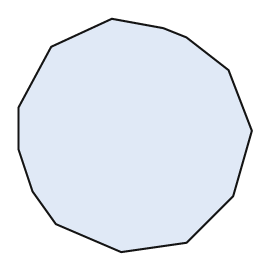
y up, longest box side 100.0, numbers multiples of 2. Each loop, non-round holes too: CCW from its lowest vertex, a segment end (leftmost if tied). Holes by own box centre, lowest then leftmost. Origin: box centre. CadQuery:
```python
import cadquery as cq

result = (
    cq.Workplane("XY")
    .moveTo(-6.0, -50.0)
    .lineTo(22.0, -46.0)
    .lineTo(42.0, -26.0)
    .lineTo(50.0, 2.0)
    .lineTo(40.0, 28.0)
    .lineTo(22.0, 42.0)
    .lineTo(12.0, 46.0)
    .lineTo(-10.0, 50.0)
    .lineTo(-36.0, 38.0)
    .lineTo(-50.0, 12.0)
    .lineTo(-50.0, -6.0)
    .lineTo(-44.0, -24.0)
    .lineTo(-34.0, -38.0)
    .close()
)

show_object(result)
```